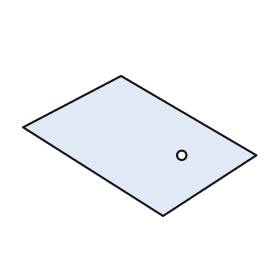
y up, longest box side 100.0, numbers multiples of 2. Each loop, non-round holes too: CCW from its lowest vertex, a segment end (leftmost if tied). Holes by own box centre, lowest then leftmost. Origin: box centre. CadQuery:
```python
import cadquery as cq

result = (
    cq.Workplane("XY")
    .moveTo(10.0, -30.0)
    .lineTo(50.0, -4.0)
    .lineTo(-8.0, 30.0)
    .lineTo(-50.0, 8.0)
    .close()
    .moveTo(18.0, -4.0)
    .circle(2.0)
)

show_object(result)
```